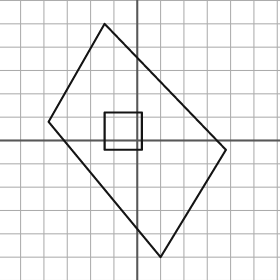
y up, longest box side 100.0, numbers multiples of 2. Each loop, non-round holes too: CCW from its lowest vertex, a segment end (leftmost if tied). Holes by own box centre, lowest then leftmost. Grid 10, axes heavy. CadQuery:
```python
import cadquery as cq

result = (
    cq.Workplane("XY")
    .moveTo(10.0, -50.0)
    .lineTo(38.0, -4.0)
    .lineTo(-14.0, 50.0)
    .lineTo(-38.0, 8.0)
    .close()
    .moveTo(-14.0, -4.0)
    .lineTo(2.0, -4.0)
    .lineTo(2.0, 12.0)
    .lineTo(-14.0, 12.0)
    .close()
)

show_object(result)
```